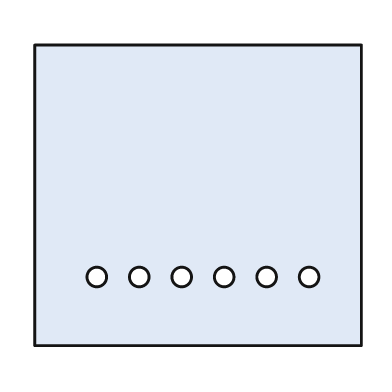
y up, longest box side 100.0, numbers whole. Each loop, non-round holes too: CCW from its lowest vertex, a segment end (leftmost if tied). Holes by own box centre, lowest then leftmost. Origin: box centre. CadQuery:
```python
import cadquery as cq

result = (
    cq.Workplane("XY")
    .moveTo(-50.0, -46.0)
    .lineTo(50.0, -46.0)
    .lineTo(50.0, 46.0)
    .lineTo(-50.0, 46.0)
    .close()
    .moveTo(-31.0, -25.0)
    .circle(3.0)
    .moveTo(-18.0, -25.0)
    .circle(3.0)
    .moveTo(-5.0, -25.0)
    .circle(3.0)
    .moveTo(8.0, -25.0)
    .circle(3.0)
    .moveTo(21.0, -25.0)
    .circle(3.0)
    .moveTo(34.0, -25.0)
    .circle(3.0)
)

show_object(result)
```